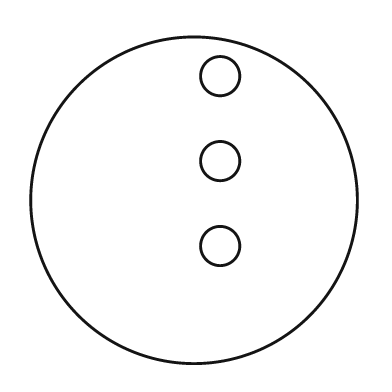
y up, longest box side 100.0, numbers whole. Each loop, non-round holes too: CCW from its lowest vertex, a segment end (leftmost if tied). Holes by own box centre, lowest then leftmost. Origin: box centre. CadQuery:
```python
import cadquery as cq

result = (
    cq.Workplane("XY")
    .moveTo(0.0, 0.0)
    .circle(50.0)
    .moveTo(8.0, -14.0)
    .circle(6.0)
    .moveTo(8.0, 12.0)
    .circle(6.0)
    .moveTo(8.0, 38.0)
    .circle(6.0)
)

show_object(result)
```